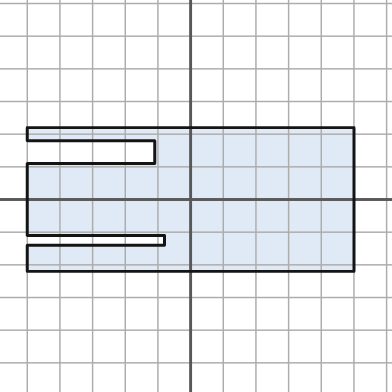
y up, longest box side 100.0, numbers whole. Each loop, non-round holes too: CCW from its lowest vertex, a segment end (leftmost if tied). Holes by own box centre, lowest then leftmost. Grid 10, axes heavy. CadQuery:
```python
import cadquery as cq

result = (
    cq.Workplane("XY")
    .moveTo(-50.0, -22.0)
    .lineTo(50.0, -22.0)
    .lineTo(50.0, 22.0)
    .lineTo(-50.0, 22.0)
    .lineTo(-50.0, 18.0)
    .lineTo(-11.0, 18.0)
    .lineTo(-11.0, 11.0)
    .lineTo(-50.0, 11.0)
    .lineTo(-50.0, -11.0)
    .lineTo(-8.0, -11.0)
    .lineTo(-8.0, -14.0)
    .lineTo(-50.0, -14.0)
    .close()
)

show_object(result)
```